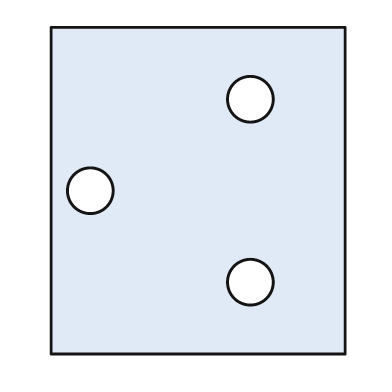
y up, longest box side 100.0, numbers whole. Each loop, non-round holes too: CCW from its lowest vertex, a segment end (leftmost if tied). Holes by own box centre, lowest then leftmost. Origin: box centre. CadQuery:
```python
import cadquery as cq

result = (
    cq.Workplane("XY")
    .moveTo(-45.0, -50.0)
    .lineTo(45.0, -50.0)
    .lineTo(45.0, 50.0)
    .lineTo(-45.0, 50.0)
    .close()
    .moveTo(16.0, -28.0)
    .circle(7.0)
    .moveTo(-33.0, 0.0)
    .circle(7.0)
    .moveTo(16.0, 28.0)
    .circle(7.0)
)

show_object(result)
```